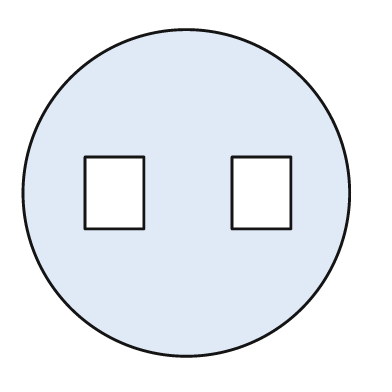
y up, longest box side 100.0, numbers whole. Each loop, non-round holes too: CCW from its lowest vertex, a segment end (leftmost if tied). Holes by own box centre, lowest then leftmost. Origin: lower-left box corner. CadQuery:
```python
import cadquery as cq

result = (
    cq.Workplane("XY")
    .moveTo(50.0, 50.0)
    .circle(50.0)
    .moveTo(19.0, 39.0)
    .lineTo(37.0, 39.0)
    .lineTo(37.0, 61.0)
    .lineTo(19.0, 61.0)
    .close()
    .moveTo(64.0, 39.0)
    .lineTo(82.0, 39.0)
    .lineTo(82.0, 61.0)
    .lineTo(64.0, 61.0)
    .close()
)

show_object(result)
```